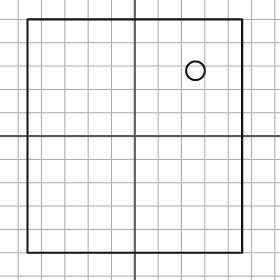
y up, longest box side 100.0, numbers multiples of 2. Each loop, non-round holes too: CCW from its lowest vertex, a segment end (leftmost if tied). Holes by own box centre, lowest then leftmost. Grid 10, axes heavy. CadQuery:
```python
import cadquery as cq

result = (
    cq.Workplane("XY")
    .moveTo(-46.0, -50.0)
    .lineTo(46.0, -50.0)
    .lineTo(46.0, 50.0)
    .lineTo(-46.0, 50.0)
    .close()
    .moveTo(26.0, 28.0)
    .circle(4.0)
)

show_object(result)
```